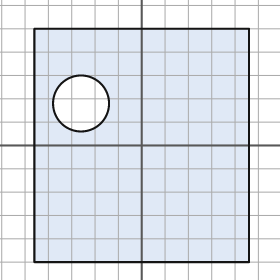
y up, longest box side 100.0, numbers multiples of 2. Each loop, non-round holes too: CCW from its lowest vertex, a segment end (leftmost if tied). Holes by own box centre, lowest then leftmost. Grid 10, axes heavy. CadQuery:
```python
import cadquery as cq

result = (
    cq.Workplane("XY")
    .moveTo(-46.0, -50.0)
    .lineTo(46.0, -50.0)
    .lineTo(46.0, 50.0)
    .lineTo(-46.0, 50.0)
    .close()
    .moveTo(-26.0, 18.0)
    .circle(12.0)
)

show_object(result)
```